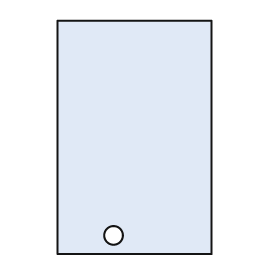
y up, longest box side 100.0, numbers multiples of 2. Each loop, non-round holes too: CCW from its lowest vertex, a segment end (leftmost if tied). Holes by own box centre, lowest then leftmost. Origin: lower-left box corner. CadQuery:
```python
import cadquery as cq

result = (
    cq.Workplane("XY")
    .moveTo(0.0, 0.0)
    .lineTo(66.0, 0.0)
    .lineTo(66.0, 100.0)
    .lineTo(0.0, 100.0)
    .close()
    .moveTo(24.0, 8.0)
    .circle(4.0)
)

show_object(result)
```